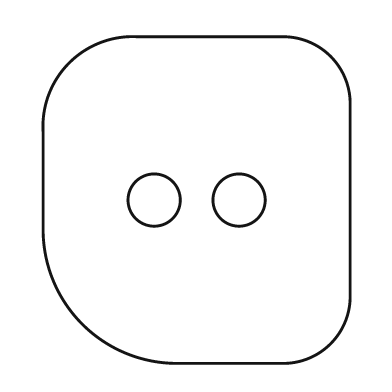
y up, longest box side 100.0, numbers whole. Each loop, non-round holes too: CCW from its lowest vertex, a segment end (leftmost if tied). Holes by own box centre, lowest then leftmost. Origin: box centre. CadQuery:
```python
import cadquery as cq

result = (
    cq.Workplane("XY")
    .moveTo(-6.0, -50.0)
    .lineTo(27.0, -50.0)
    .threePointArc((41.0, -44.0), (47.0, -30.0))
    .lineTo(47.0, 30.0)
    .threePointArc((41.0, 44.0), (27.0, 50.0))
    .lineTo(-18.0, 50.0)
    .threePointArc((-39.0, 42.0), (-47.0, 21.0))
    .lineTo(-47.0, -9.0)
    .threePointArc((-35.0, -38.0), (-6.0, -50.0))
    .close()
    .moveTo(-13.0, 0.0)
    .circle(8.0)
    .moveTo(13.0, 0.0)
    .circle(8.0)
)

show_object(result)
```